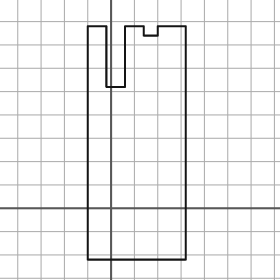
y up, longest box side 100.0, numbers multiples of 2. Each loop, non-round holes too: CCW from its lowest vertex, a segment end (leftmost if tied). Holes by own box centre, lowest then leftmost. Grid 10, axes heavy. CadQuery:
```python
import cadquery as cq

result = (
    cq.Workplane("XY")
    .moveTo(-10.0, -22.0)
    .lineTo(32.0, -22.0)
    .lineTo(32.0, 78.0)
    .lineTo(20.0, 78.0)
    .lineTo(20.0, 74.0)
    .lineTo(14.0, 74.0)
    .lineTo(14.0, 78.0)
    .lineTo(6.0, 78.0)
    .lineTo(6.0, 52.0)
    .lineTo(-2.0, 52.0)
    .lineTo(-2.0, 78.0)
    .lineTo(-10.0, 78.0)
    .close()
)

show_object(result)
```